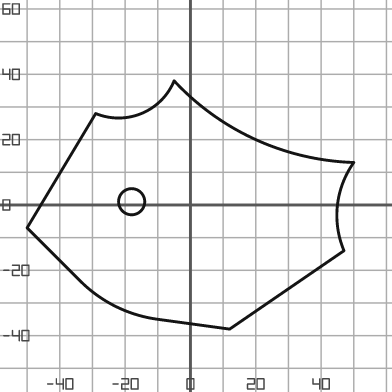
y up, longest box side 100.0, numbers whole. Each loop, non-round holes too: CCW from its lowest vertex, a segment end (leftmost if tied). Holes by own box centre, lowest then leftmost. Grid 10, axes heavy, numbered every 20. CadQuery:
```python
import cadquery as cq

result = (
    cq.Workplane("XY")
    .moveTo(12.0, -38.0)
    .lineTo(47.0, -14.0)
    .threePointArc((45.0, 0.0), (50.0, 13.0))
    .threePointArc((20.0, 20.0), (-5.0, 38.0))
    .threePointArc((-15.0, 28.0), (-29.0, 28.0))
    .lineTo(-50.0, -7.0)
    .lineTo(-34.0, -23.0)
    .threePointArc((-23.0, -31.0), (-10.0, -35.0))
    .close()
    .moveTo(-18.0, 1.0)
    .circle(4.0)
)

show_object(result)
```